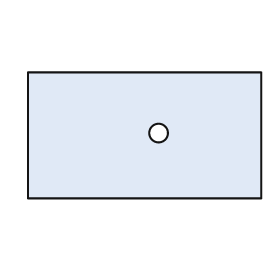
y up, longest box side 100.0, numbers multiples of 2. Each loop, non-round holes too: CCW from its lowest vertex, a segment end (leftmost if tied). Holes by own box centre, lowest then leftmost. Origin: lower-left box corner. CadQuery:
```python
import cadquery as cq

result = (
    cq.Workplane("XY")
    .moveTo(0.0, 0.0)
    .lineTo(100.0, 0.0)
    .lineTo(100.0, 54.0)
    .lineTo(0.0, 54.0)
    .close()
    .moveTo(56.0, 28.0)
    .circle(4.0)
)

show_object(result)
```